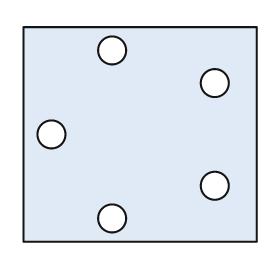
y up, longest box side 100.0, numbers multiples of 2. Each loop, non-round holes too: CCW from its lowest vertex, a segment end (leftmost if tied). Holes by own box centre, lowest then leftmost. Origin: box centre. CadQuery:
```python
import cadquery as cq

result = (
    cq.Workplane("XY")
    .moveTo(-50.0, -46.0)
    .lineTo(50.0, -46.0)
    .lineTo(50.0, 46.0)
    .lineTo(-50.0, 46.0)
    .close()
    .moveTo(-12.0, -36.0)
    .circle(6.0)
    .moveTo(32.0, -22.0)
    .circle(6.0)
    .moveTo(-38.0, 0.0)
    .circle(6.0)
    .moveTo(32.0, 22.0)
    .circle(6.0)
    .moveTo(-12.0, 36.0)
    .circle(6.0)
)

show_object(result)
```